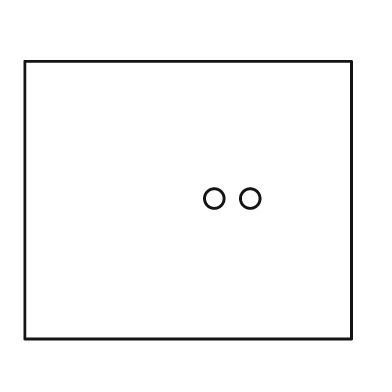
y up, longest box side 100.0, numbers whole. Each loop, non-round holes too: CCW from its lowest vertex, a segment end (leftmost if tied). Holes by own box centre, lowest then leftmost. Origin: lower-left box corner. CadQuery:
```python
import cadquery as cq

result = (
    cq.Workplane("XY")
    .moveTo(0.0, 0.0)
    .lineTo(100.0, 0.0)
    .lineTo(100.0, 85.0)
    .lineTo(0.0, 85.0)
    .close()
    .moveTo(58.0, 43.0)
    .circle(3.0)
    .moveTo(69.0, 43.0)
    .circle(3.0)
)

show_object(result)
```